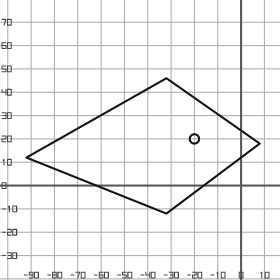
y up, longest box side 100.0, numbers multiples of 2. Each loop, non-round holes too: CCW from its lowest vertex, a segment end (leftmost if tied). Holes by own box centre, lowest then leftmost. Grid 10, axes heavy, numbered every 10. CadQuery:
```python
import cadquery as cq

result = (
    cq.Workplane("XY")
    .moveTo(-32.0, -12.0)
    .lineTo(8.0, 18.0)
    .lineTo(-32.0, 46.0)
    .lineTo(-92.0, 12.0)
    .close()
    .moveTo(-20.0, 20.0)
    .circle(2.0)
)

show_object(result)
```